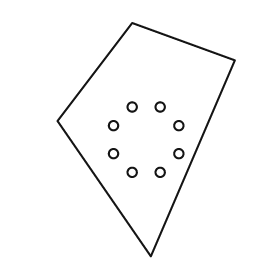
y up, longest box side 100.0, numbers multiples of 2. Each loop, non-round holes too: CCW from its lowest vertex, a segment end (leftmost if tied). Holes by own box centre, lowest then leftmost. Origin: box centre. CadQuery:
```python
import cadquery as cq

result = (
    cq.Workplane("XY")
    .moveTo(2.0, -50.0)
    .lineTo(38.0, 34.0)
    .lineTo(-6.0, 50.0)
    .lineTo(-38.0, 8.0)
    .close()
    .moveTo(-6.0, -14.0)
    .circle(2.0)
    .moveTo(6.0, -14.0)
    .circle(2.0)
    .moveTo(-14.0, -6.0)
    .circle(2.0)
    .moveTo(14.0, -6.0)
    .circle(2.0)
    .moveTo(-14.0, 6.0)
    .circle(2.0)
    .moveTo(14.0, 6.0)
    .circle(2.0)
    .moveTo(-6.0, 14.0)
    .circle(2.0)
    .moveTo(6.0, 14.0)
    .circle(2.0)
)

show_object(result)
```